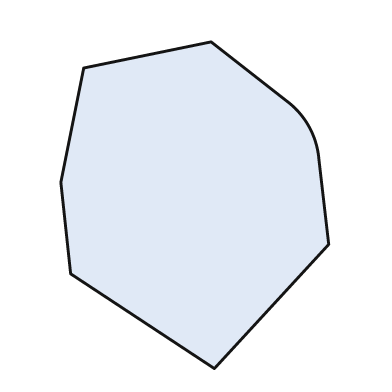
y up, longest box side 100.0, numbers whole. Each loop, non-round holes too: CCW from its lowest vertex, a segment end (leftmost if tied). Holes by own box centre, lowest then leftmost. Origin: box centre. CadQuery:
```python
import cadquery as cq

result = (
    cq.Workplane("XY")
    .moveTo(6.0, -50.0)
    .lineTo(41.0, -12.0)
    .lineTo(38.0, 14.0)
    .threePointArc((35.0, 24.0), (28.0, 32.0))
    .lineTo(5.0, 50.0)
    .lineTo(-34.0, 42.0)
    .lineTo(-41.0, 7.0)
    .lineTo(-38.0, -21.0)
    .close()
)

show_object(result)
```